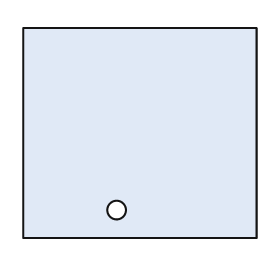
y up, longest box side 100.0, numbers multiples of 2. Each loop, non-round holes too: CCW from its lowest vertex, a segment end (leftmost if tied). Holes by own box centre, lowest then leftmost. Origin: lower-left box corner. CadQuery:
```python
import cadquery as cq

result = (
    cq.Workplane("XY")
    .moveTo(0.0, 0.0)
    .lineTo(100.0, 0.0)
    .lineTo(100.0, 90.0)
    .lineTo(0.0, 90.0)
    .close()
    .moveTo(40.0, 12.0)
    .circle(4.0)
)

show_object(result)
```